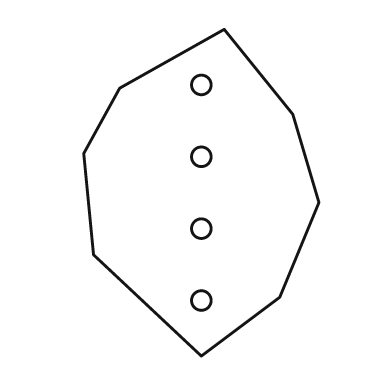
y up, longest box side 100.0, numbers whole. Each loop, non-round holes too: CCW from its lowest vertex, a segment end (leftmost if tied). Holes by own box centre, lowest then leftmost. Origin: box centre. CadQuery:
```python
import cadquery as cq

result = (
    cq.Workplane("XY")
    .moveTo(0.0, -50.0)
    .lineTo(24.0, -32.0)
    .lineTo(36.0, -3.0)
    .lineTo(28.0, 24.0)
    .lineTo(7.0, 50.0)
    .lineTo(-25.0, 32.0)
    .lineTo(-36.0, 12.0)
    .lineTo(-33.0, -19.0)
    .close()
    .moveTo(0.0, -33.0)
    .circle(3.0)
    .moveTo(0.0, -11.0)
    .circle(3.0)
    .moveTo(0.0, 11.0)
    .circle(3.0)
    .moveTo(0.0, 33.0)
    .circle(3.0)
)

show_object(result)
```